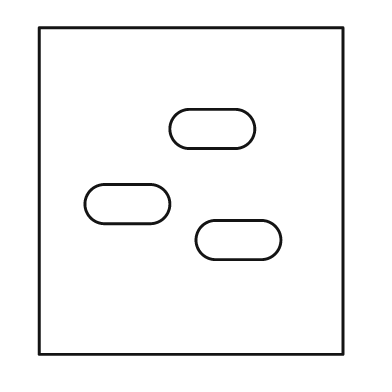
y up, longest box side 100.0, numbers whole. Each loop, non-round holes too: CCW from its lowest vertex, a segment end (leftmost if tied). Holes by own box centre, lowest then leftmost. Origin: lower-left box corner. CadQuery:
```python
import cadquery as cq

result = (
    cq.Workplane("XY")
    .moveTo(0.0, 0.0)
    .lineTo(93.0, 0.0)
    .lineTo(93.0, 100.0)
    .lineTo(0.0, 100.0)
    .close()
    .moveTo(54.0, 29.0)
    .lineTo(68.0, 29.0)
    .threePointArc((74.0, 35.0), (68.0, 41.0))
    .lineTo(54.0, 41.0)
    .threePointArc((48.0, 35.0), (54.0, 29.0))
    .close()
    .moveTo(20.0, 40.0)
    .lineTo(34.0, 40.0)
    .threePointArc((40.0, 46.0), (34.0, 52.0))
    .lineTo(20.0, 52.0)
    .threePointArc((14.0, 46.0), (20.0, 40.0))
    .close()
    .moveTo(46.0, 63.0)
    .lineTo(60.0, 63.0)
    .threePointArc((66.0, 69.0), (60.0, 75.0))
    .lineTo(46.0, 75.0)
    .threePointArc((40.0, 69.0), (46.0, 63.0))
    .close()
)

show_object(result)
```